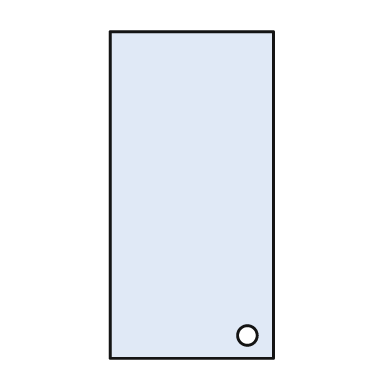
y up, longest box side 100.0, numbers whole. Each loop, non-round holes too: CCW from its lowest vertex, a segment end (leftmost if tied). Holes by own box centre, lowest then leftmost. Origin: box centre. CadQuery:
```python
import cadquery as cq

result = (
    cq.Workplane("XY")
    .moveTo(-25.0, -50.0)
    .lineTo(25.0, -50.0)
    .lineTo(25.0, 50.0)
    .lineTo(-25.0, 50.0)
    .close()
    .moveTo(17.0, -43.0)
    .circle(3.0)
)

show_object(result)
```